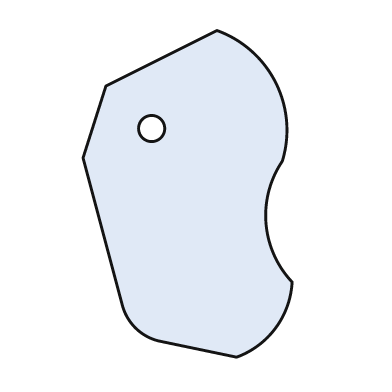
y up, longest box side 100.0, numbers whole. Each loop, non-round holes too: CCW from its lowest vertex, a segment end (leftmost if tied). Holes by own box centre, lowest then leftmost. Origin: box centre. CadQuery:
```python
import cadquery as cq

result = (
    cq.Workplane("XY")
    .moveTo(15.0, -50.0)
    .threePointArc((27.0, -41.0), (32.0, -27.0))
    .threePointArc((24.0, -9.0), (29.0, 10.0))
    .threePointArc((27.0, 34.0), (9.0, 50.0))
    .lineTo(-25.0, 33.0)
    .lineTo(-32.0, 11.0)
    .lineTo(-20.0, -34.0)
    .threePointArc((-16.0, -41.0), (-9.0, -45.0))
    .close()
    .moveTo(-11.0, 20.0)
    .circle(4.0)
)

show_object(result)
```